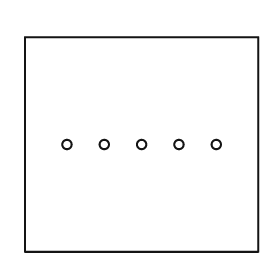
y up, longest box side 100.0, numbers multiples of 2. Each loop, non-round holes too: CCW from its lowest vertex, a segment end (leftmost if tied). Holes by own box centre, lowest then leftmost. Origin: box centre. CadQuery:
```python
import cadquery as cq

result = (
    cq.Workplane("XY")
    .moveTo(-50.0, -46.0)
    .lineTo(50.0, -46.0)
    .lineTo(50.0, 46.0)
    .lineTo(-50.0, 46.0)
    .close()
    .moveTo(-32.0, 0.0)
    .circle(2.0)
    .moveTo(-16.0, 0.0)
    .circle(2.0)
    .moveTo(0.0, 0.0)
    .circle(2.0)
    .moveTo(16.0, 0.0)
    .circle(2.0)
    .moveTo(32.0, 0.0)
    .circle(2.0)
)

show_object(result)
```